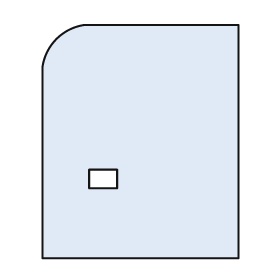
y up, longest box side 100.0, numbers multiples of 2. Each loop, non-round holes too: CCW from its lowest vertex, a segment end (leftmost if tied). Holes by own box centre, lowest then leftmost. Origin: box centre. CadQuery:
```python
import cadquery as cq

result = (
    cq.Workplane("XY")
    .moveTo(-42.0, -50.0)
    .lineTo(42.0, -50.0)
    .lineTo(42.0, 50.0)
    .lineTo(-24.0, 50.0)
    .threePointArc((-36.0, 44.0), (-42.0, 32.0))
    .close()
    .moveTo(-22.0, -20.0)
    .lineTo(-10.0, -20.0)
    .lineTo(-10.0, -12.0)
    .lineTo(-22.0, -12.0)
    .close()
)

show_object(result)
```